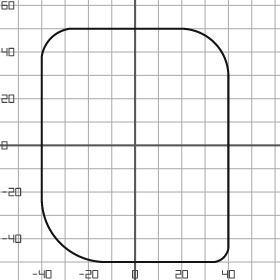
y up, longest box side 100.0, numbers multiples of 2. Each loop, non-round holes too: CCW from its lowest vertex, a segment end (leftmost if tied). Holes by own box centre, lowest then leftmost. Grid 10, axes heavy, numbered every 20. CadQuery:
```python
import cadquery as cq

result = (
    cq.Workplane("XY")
    .moveTo(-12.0, -50.0)
    .lineTo(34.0, -50.0)
    .threePointArc((38.0, -48.0), (40.0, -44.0))
    .lineTo(40.0, 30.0)
    .threePointArc((34.0, 44.0), (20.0, 50.0))
    .lineTo(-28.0, 50.0)
    .threePointArc((-36.0, 46.0), (-40.0, 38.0))
    .lineTo(-40.0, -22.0)
    .threePointArc((-32.0, -42.0), (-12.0, -50.0))
    .close()
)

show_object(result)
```